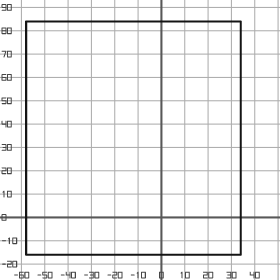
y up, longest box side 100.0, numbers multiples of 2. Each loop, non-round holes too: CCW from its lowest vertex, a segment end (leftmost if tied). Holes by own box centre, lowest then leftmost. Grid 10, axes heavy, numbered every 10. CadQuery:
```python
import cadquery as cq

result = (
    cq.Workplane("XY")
    .moveTo(-58.0, -16.0)
    .lineTo(34.0, -16.0)
    .lineTo(34.0, 84.0)
    .lineTo(-58.0, 84.0)
    .close()
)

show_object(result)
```